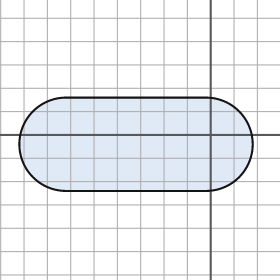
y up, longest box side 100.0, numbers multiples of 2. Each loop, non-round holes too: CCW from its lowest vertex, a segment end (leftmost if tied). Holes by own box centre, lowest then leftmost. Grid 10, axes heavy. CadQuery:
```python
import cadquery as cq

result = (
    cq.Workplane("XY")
    .moveTo(-62.0, -24.0)
    .lineTo(-2.0, -24.0)
    .threePointArc((18.0, -4.0), (-2.0, 16.0))
    .lineTo(-62.0, 16.0)
    .threePointArc((-82.0, -4.0), (-62.0, -24.0))
    .close()
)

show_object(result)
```